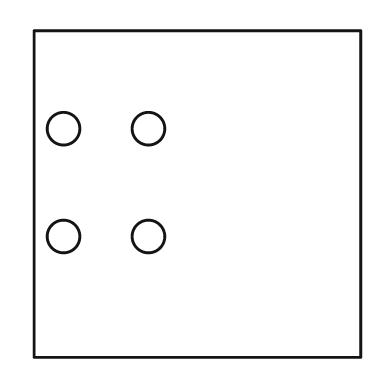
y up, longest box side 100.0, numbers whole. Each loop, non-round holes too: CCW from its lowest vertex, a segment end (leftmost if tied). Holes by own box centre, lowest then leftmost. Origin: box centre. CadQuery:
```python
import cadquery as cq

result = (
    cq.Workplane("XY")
    .moveTo(-50.0, -50.0)
    .lineTo(50.0, -50.0)
    .lineTo(50.0, 50.0)
    .lineTo(-50.0, 50.0)
    .close()
    .moveTo(-41.0, -13.0)
    .circle(5.0)
    .moveTo(-15.0, -13.0)
    .circle(5.0)
    .moveTo(-41.0, 20.0)
    .circle(5.0)
    .moveTo(-15.0, 20.0)
    .circle(5.0)
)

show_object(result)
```